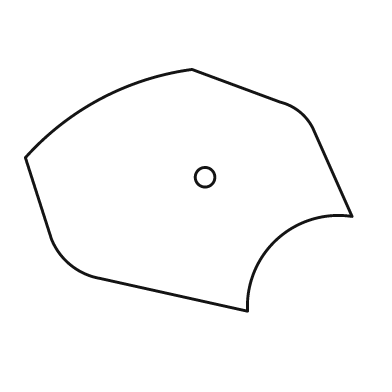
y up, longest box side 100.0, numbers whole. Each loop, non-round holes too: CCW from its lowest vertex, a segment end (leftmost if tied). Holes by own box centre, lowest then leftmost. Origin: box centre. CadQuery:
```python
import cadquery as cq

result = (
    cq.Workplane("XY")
    .moveTo(18.0, -37.0)
    .threePointArc((27.0, -15.0), (50.0, -8.0))
    .lineTo(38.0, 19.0)
    .threePointArc((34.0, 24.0), (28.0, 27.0))
    .lineTo(1.0, 37.0)
    .threePointArc((-27.0, 28.0), (-50.0, 10.0))
    .lineTo(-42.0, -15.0)
    .threePointArc((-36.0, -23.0), (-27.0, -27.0))
    .close()
    .moveTo(5.0, 4.0)
    .circle(3.0)
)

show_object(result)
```